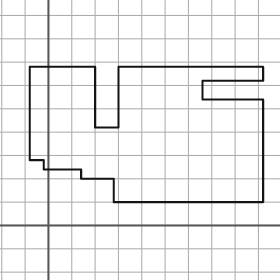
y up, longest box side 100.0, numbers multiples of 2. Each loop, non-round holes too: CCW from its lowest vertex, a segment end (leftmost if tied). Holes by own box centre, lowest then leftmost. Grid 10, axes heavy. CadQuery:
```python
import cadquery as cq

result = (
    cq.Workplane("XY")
    .moveTo(28.0, 10.0)
    .lineTo(92.0, 10.0)
    .lineTo(92.0, 54.0)
    .lineTo(66.0, 54.0)
    .lineTo(66.0, 62.0)
    .lineTo(92.0, 62.0)
    .lineTo(92.0, 68.0)
    .lineTo(30.0, 68.0)
    .lineTo(30.0, 42.0)
    .lineTo(20.0, 42.0)
    .lineTo(20.0, 68.0)
    .lineTo(-8.0, 68.0)
    .lineTo(-8.0, 28.0)
    .lineTo(-2.0, 28.0)
    .lineTo(-2.0, 24.0)
    .lineTo(14.0, 24.0)
    .lineTo(14.0, 20.0)
    .lineTo(28.0, 20.0)
    .close()
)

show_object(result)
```